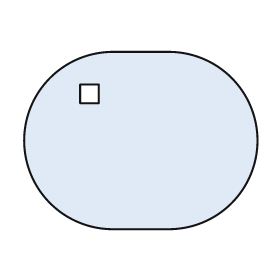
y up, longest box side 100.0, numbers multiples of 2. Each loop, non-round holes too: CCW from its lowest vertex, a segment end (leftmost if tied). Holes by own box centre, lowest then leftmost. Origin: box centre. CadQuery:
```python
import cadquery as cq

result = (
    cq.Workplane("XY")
    .moveTo(-12.0, -38.0)
    .lineTo(12.0, -38.0)
    .threePointArc((50.0, 0.0), (12.0, 38.0))
    .lineTo(-12.0, 38.0)
    .threePointArc((-50.0, 0.0), (-12.0, -38.0))
    .close()
    .moveTo(-26.0, 16.0)
    .lineTo(-18.0, 16.0)
    .lineTo(-18.0, 24.0)
    .lineTo(-26.0, 24.0)
    .close()
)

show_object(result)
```